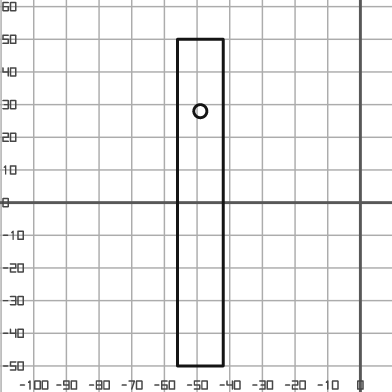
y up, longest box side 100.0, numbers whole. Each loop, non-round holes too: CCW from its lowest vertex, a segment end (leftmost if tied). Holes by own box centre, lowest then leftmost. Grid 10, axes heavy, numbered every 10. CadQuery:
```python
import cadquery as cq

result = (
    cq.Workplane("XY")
    .moveTo(-56.0, -50.0)
    .lineTo(-42.0, -50.0)
    .lineTo(-42.0, 50.0)
    .lineTo(-56.0, 50.0)
    .close()
    .moveTo(-49.0, 28.0)
    .circle(2.0)
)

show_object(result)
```